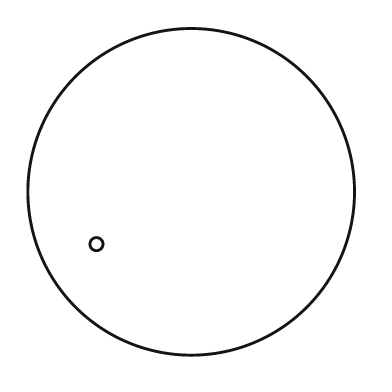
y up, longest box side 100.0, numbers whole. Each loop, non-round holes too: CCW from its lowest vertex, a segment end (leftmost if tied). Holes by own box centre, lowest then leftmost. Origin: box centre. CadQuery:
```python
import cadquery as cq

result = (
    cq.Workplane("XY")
    .moveTo(0.0, 0.0)
    .circle(50.0)
    .moveTo(-29.0, -16.0)
    .circle(2.0)
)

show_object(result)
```